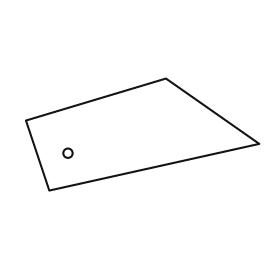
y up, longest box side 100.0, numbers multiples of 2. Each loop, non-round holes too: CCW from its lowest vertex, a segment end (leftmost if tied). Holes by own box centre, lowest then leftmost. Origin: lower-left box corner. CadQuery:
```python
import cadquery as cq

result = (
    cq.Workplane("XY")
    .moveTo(10.0, 0.0)
    .lineTo(100.0, 20.0)
    .lineTo(60.0, 48.0)
    .lineTo(0.0, 30.0)
    .close()
    .moveTo(18.0, 16.0)
    .circle(2.0)
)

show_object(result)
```